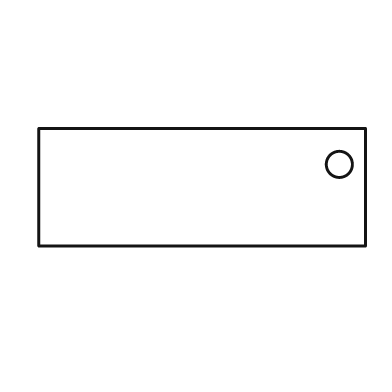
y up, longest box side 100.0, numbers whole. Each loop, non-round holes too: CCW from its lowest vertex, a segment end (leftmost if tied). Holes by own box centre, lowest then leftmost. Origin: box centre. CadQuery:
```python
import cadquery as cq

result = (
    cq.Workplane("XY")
    .moveTo(-50.0, -18.0)
    .lineTo(50.0, -18.0)
    .lineTo(50.0, 18.0)
    .lineTo(-50.0, 18.0)
    .close()
    .moveTo(42.0, 7.0)
    .circle(4.0)
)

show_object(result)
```